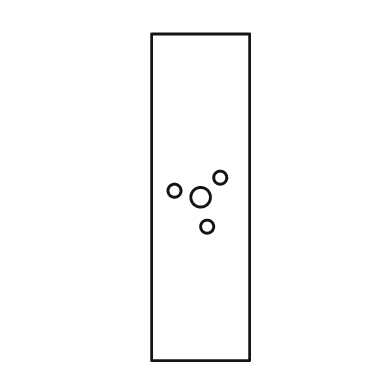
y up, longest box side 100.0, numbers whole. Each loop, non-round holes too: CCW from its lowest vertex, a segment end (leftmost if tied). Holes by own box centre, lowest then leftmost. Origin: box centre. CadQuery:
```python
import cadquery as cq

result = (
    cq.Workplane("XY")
    .moveTo(-15.0, -50.0)
    .lineTo(15.0, -50.0)
    .lineTo(15.0, 50.0)
    .lineTo(-15.0, 50.0)
    .close()
    .moveTo(2.0, -9.0)
    .circle(2.0)
    .moveTo(0.0, 0.0)
    .circle(3.0)
    .moveTo(-8.0, 2.0)
    .circle(2.0)
    .moveTo(6.0, 6.0)
    .circle(2.0)
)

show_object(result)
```